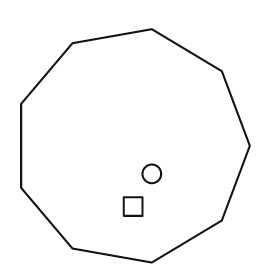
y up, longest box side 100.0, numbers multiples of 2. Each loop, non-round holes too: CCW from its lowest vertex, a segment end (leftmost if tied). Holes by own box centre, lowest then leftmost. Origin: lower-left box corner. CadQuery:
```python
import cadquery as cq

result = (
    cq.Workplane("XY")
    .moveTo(56.0, 0.0)
    .lineTo(86.0, 18.0)
    .lineTo(98.0, 50.0)
    .lineTo(86.0, 82.0)
    .lineTo(56.0, 100.0)
    .lineTo(22.0, 94.0)
    .lineTo(0.0, 68.0)
    .lineTo(0.0, 32.0)
    .lineTo(22.0, 6.0)
    .close()
    .moveTo(44.0, 20.0)
    .lineTo(52.0, 20.0)
    .lineTo(52.0, 28.0)
    .lineTo(44.0, 28.0)
    .close()
    .moveTo(56.0, 38.0)
    .circle(4.0)
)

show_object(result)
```